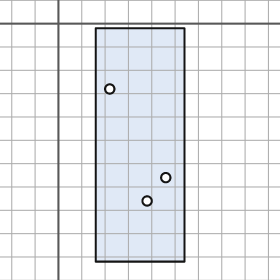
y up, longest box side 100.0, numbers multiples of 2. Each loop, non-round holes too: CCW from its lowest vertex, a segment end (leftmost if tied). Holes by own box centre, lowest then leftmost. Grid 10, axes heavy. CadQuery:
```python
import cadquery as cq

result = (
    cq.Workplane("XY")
    .moveTo(16.0, -102.0)
    .lineTo(54.0, -102.0)
    .lineTo(54.0, -2.0)
    .lineTo(16.0, -2.0)
    .close()
    .moveTo(38.0, -76.0)
    .circle(2.0)
    .moveTo(46.0, -66.0)
    .circle(2.0)
    .moveTo(22.0, -28.0)
    .circle(2.0)
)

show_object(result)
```